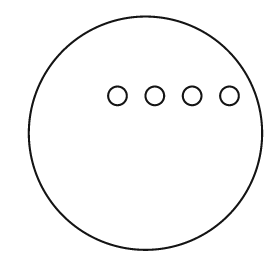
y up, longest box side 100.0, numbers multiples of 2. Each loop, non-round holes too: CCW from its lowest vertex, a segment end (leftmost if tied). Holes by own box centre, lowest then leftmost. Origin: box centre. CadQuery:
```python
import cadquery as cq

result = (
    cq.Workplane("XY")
    .moveTo(0.0, 0.0)
    .circle(50.0)
    .moveTo(-12.0, 16.0)
    .circle(4.0)
    .moveTo(4.0, 16.0)
    .circle(4.0)
    .moveTo(20.0, 16.0)
    .circle(4.0)
    .moveTo(36.0, 16.0)
    .circle(4.0)
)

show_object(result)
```